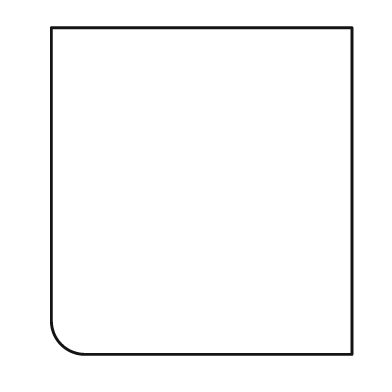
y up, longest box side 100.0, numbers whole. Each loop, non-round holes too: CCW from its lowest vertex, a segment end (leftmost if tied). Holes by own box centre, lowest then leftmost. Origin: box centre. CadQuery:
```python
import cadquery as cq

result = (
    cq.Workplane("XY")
    .moveTo(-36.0, -50.0)
    .lineTo(46.0, -50.0)
    .lineTo(46.0, 50.0)
    .lineTo(-46.0, 50.0)
    .lineTo(-46.0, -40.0)
    .threePointArc((-43.0, -47.0), (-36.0, -50.0))
    .close()
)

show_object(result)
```